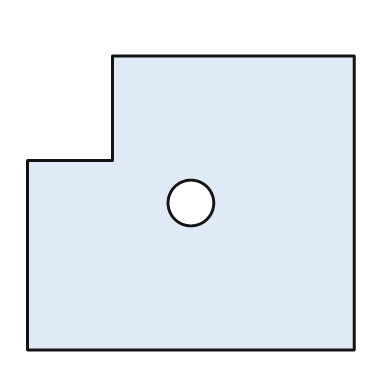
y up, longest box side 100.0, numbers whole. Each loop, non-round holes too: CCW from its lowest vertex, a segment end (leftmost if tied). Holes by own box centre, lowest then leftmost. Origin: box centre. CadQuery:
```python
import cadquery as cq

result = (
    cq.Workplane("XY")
    .moveTo(-50.0, -45.0)
    .lineTo(50.0, -45.0)
    .lineTo(50.0, 45.0)
    .lineTo(-24.0, 45.0)
    .lineTo(-24.0, 13.0)
    .lineTo(-50.0, 13.0)
    .close()
    .moveTo(0.0, 0.0)
    .circle(7.0)
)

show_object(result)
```